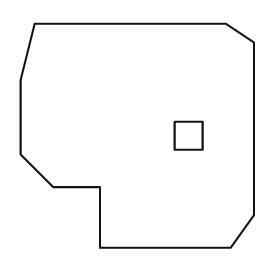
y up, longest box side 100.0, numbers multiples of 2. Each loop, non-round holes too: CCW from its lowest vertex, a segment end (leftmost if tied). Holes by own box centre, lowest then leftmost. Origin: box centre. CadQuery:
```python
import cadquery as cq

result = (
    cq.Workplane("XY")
    .moveTo(-16.0, -48.0)
    .lineTo(40.0, -48.0)
    .lineTo(50.0, -34.0)
    .lineTo(50.0, 40.0)
    .lineTo(38.0, 48.0)
    .lineTo(-44.0, 48.0)
    .lineTo(-50.0, 24.0)
    .lineTo(-50.0, -8.0)
    .lineTo(-36.0, -22.0)
    .lineTo(-16.0, -22.0)
    .close()
    .moveTo(16.0, -6.0)
    .lineTo(28.0, -6.0)
    .lineTo(28.0, 6.0)
    .lineTo(16.0, 6.0)
    .close()
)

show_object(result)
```